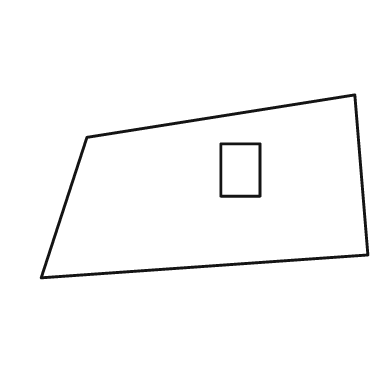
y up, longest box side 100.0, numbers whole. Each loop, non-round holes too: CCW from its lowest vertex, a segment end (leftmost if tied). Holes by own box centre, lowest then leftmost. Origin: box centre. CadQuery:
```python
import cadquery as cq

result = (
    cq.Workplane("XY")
    .moveTo(-50.0, -28.0)
    .lineTo(50.0, -21.0)
    .lineTo(46.0, 28.0)
    .lineTo(-36.0, 15.0)
    .close()
    .moveTo(5.0, -3.0)
    .lineTo(17.0, -3.0)
    .lineTo(17.0, 13.0)
    .lineTo(5.0, 13.0)
    .close()
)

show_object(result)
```